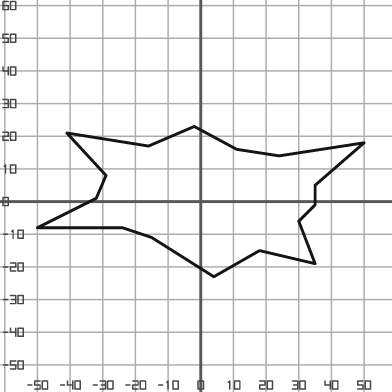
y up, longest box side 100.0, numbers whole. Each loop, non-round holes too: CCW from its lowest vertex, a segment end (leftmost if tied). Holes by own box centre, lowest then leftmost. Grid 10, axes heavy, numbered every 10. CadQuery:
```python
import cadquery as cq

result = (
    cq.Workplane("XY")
    .moveTo(4.0, -23.0)
    .lineTo(18.0, -15.0)
    .lineTo(35.0, -19.0)
    .lineTo(30.0, -6.0)
    .lineTo(35.0, -1.0)
    .lineTo(35.0, 5.0)
    .lineTo(50.0, 18.0)
    .lineTo(24.0, 14.0)
    .lineTo(11.0, 16.0)
    .lineTo(-2.0, 23.0)
    .lineTo(-16.0, 17.0)
    .lineTo(-41.0, 21.0)
    .lineTo(-29.0, 8.0)
    .lineTo(-32.0, 1.0)
    .lineTo(-50.0, -8.0)
    .lineTo(-24.0, -8.0)
    .lineTo(-15.0, -11.0)
    .close()
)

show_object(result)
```